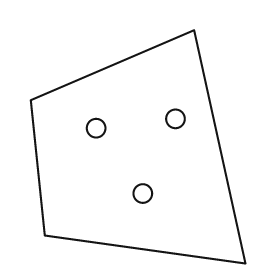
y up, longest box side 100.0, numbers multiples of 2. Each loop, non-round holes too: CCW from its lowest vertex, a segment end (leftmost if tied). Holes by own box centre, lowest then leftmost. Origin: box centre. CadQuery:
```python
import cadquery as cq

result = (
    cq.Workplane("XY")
    .moveTo(46.0, -50.0)
    .lineTo(24.0, 50.0)
    .lineTo(-46.0, 20.0)
    .lineTo(-40.0, -38.0)
    .close()
    .moveTo(2.0, -20.0)
    .circle(4.0)
    .moveTo(-18.0, 8.0)
    .circle(4.0)
    .moveTo(16.0, 12.0)
    .circle(4.0)
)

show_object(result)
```